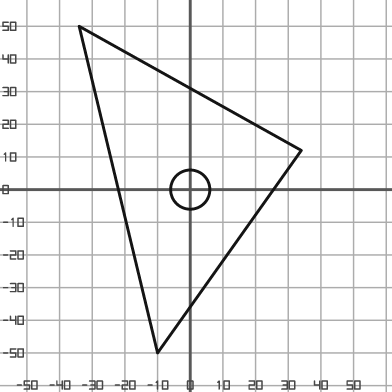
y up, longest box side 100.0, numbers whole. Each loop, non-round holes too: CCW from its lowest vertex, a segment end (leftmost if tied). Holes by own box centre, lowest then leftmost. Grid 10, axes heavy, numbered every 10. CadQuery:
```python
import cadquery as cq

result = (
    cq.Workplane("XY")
    .moveTo(-10.0, -50.0)
    .lineTo(34.0, 12.0)
    .lineTo(-34.0, 50.0)
    .close()
    .moveTo(0.0, 0.0)
    .circle(6.0)
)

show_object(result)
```